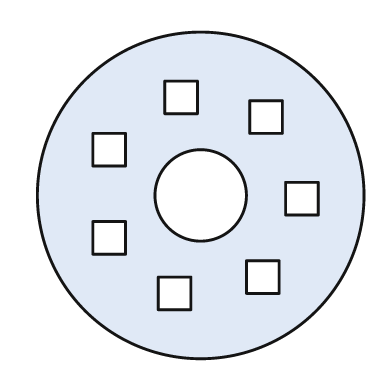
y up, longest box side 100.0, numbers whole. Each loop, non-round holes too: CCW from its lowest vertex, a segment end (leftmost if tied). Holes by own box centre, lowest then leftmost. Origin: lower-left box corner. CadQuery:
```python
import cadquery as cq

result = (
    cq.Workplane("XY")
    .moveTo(50.0, 50.0)
    .circle(50.0)
    .moveTo(37.0, 15.0)
    .lineTo(47.0, 15.0)
    .lineTo(47.0, 25.0)
    .lineTo(37.0, 25.0)
    .close()
    .moveTo(64.0, 20.0)
    .lineTo(74.0, 20.0)
    .lineTo(74.0, 30.0)
    .lineTo(64.0, 30.0)
    .close()
    .moveTo(17.0, 32.0)
    .lineTo(27.0, 32.0)
    .lineTo(27.0, 42.0)
    .lineTo(17.0, 42.0)
    .close()
    .moveTo(76.0, 44.0)
    .lineTo(86.0, 44.0)
    .lineTo(86.0, 54.0)
    .lineTo(76.0, 54.0)
    .close()
    .moveTo(50.0, 50.0)
    .circle(14.0)
    .moveTo(17.0, 59.0)
    .lineTo(27.0, 59.0)
    .lineTo(27.0, 69.0)
    .lineTo(17.0, 69.0)
    .close()
    .moveTo(65.0, 69.0)
    .lineTo(75.0, 69.0)
    .lineTo(75.0, 79.0)
    .lineTo(65.0, 79.0)
    .close()
    .moveTo(39.0, 75.0)
    .lineTo(49.0, 75.0)
    .lineTo(49.0, 85.0)
    .lineTo(39.0, 85.0)
    .close()
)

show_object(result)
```